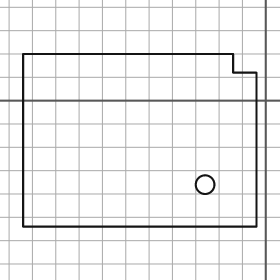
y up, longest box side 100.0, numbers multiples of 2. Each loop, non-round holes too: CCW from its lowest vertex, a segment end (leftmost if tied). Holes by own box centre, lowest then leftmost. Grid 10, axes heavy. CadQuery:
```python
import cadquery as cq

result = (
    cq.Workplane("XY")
    .moveTo(-104.0, -54.0)
    .lineTo(-4.0, -54.0)
    .lineTo(-4.0, 12.0)
    .lineTo(-14.0, 12.0)
    .lineTo(-14.0, 20.0)
    .lineTo(-104.0, 20.0)
    .close()
    .moveTo(-26.0, -36.0)
    .circle(4.0)
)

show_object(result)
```